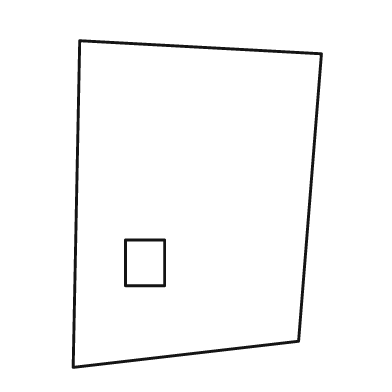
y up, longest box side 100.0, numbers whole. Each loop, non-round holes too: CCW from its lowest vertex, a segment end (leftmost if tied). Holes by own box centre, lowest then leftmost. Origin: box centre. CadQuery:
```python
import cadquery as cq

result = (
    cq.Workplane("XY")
    .moveTo(-38.0, -50.0)
    .lineTo(31.0, -42.0)
    .lineTo(38.0, 46.0)
    .lineTo(-36.0, 50.0)
    .close()
    .moveTo(-22.0, -25.0)
    .lineTo(-10.0, -25.0)
    .lineTo(-10.0, -11.0)
    .lineTo(-22.0, -11.0)
    .close()
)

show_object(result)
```